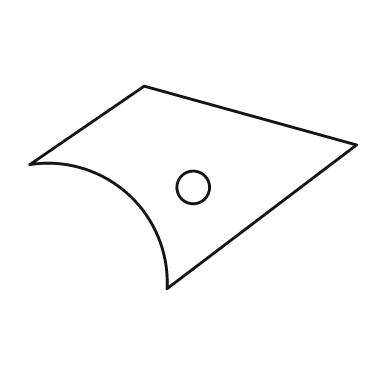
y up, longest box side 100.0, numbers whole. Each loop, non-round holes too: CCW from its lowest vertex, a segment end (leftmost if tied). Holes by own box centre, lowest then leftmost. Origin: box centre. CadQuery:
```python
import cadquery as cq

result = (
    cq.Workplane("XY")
    .moveTo(-8.0, -31.0)
    .lineTo(50.0, 13.0)
    .lineTo(-15.0, 31.0)
    .lineTo(-50.0, 7.0)
    .threePointArc((-20.0, -2.0), (-8.0, -31.0))
    .close()
    .moveTo(0.0, 0.0)
    .circle(5.0)
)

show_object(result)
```